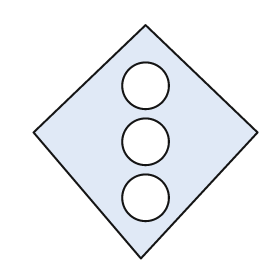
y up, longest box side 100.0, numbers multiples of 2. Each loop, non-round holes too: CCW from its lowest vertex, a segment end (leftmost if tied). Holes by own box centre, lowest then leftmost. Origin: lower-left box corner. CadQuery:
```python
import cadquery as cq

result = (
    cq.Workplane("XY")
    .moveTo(46.0, 0.0)
    .lineTo(96.0, 54.0)
    .lineTo(48.0, 100.0)
    .lineTo(0.0, 54.0)
    .close()
    .moveTo(48.0, 26.0)
    .circle(10.0)
    .moveTo(48.0, 50.0)
    .circle(10.0)
    .moveTo(48.0, 74.0)
    .circle(10.0)
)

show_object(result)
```